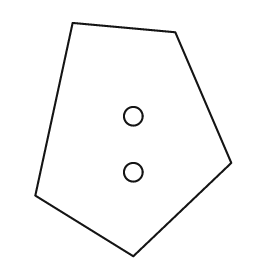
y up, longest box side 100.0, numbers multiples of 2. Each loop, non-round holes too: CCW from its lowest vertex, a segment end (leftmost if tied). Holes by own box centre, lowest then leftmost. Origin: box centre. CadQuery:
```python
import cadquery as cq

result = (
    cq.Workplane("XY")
    .moveTo(0.0, -50.0)
    .lineTo(42.0, -10.0)
    .lineTo(18.0, 46.0)
    .lineTo(-26.0, 50.0)
    .lineTo(-42.0, -24.0)
    .close()
    .moveTo(0.0, -14.0)
    .circle(4.0)
    .moveTo(0.0, 10.0)
    .circle(4.0)
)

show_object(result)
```